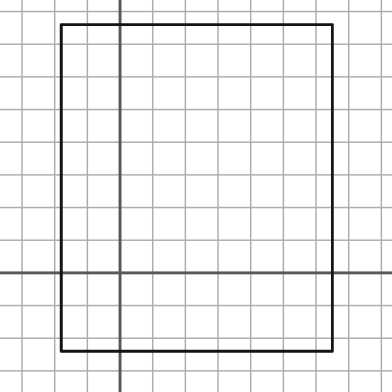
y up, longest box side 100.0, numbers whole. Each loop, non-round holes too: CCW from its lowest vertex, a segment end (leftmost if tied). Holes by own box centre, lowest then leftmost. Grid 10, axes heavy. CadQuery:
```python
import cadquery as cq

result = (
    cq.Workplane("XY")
    .moveTo(-18.0, -24.0)
    .lineTo(65.0, -24.0)
    .lineTo(65.0, 76.0)
    .lineTo(-18.0, 76.0)
    .close()
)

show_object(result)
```